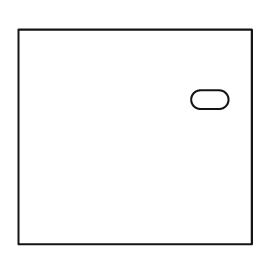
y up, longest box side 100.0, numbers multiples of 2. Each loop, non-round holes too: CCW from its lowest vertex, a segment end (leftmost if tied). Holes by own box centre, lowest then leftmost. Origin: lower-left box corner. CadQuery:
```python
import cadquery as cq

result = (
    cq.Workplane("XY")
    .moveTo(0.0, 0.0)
    .lineTo(100.0, 0.0)
    .lineTo(100.0, 92.0)
    .lineTo(0.0, 92.0)
    .close()
    .moveTo(78.0, 58.0)
    .lineTo(86.0, 58.0)
    .threePointArc((90.0, 62.0), (86.0, 66.0))
    .lineTo(78.0, 66.0)
    .threePointArc((74.0, 62.0), (78.0, 58.0))
    .close()
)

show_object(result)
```